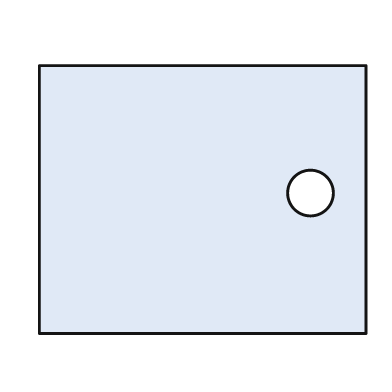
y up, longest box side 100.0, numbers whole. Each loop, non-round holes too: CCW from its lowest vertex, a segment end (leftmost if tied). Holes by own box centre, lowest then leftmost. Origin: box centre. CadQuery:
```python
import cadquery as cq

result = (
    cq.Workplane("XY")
    .moveTo(-50.0, -41.0)
    .lineTo(50.0, -41.0)
    .lineTo(50.0, 41.0)
    .lineTo(-50.0, 41.0)
    .close()
    .moveTo(33.0, 2.0)
    .circle(7.0)
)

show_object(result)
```